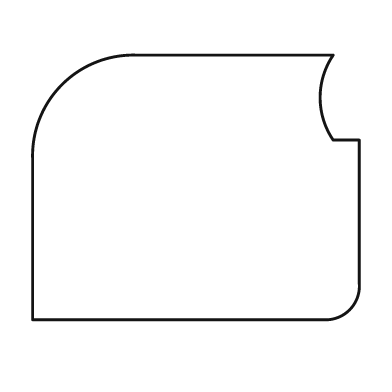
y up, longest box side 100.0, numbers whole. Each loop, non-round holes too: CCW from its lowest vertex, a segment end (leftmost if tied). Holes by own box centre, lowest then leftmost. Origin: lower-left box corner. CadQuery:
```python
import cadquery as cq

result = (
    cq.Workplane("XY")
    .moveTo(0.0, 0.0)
    .lineTo(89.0, 0.0)
    .threePointArc((97.0, 3.0), (100.0, 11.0))
    .lineTo(100.0, 55.0)
    .lineTo(92.0, 55.0)
    .threePointArc((88.0, 68.0), (92.0, 81.0))
    .lineTo(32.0, 81.0)
    .threePointArc((9.0, 72.0), (0.0, 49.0))
    .close()
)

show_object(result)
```